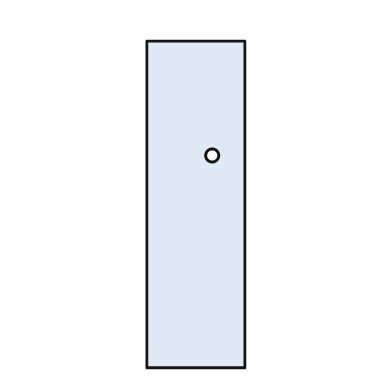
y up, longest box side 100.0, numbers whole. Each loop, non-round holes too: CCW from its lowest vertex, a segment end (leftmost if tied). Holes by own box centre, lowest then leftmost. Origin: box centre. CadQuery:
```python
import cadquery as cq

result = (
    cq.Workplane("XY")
    .moveTo(-15.0, -50.0)
    .lineTo(15.0, -50.0)
    .lineTo(15.0, 50.0)
    .lineTo(-15.0, 50.0)
    .close()
    .moveTo(5.0, 15.0)
    .circle(2.0)
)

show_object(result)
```